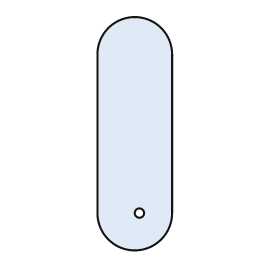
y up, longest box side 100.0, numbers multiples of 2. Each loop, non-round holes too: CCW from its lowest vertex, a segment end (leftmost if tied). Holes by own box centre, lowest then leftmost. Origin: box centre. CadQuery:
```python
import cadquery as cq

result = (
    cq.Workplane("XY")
    .moveTo(-16.0, -34.0)
    .threePointArc((0.0, -50.0), (16.0, -34.0))
    .lineTo(16.0, 34.0)
    .threePointArc((0.0, 50.0), (-16.0, 34.0))
    .close()
    .moveTo(2.0, -34.0)
    .circle(2.0)
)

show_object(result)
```